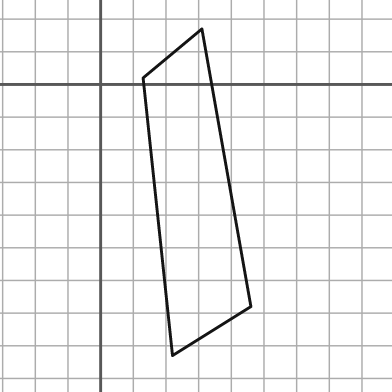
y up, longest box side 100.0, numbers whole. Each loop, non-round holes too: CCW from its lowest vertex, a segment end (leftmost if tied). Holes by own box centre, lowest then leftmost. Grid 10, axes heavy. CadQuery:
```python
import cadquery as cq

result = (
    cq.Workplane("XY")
    .moveTo(22.0, -83.0)
    .lineTo(46.0, -68.0)
    .lineTo(31.0, 17.0)
    .lineTo(13.0, 2.0)
    .close()
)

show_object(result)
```